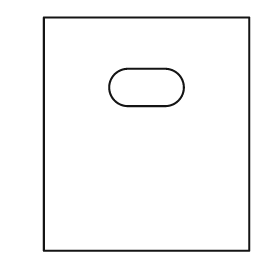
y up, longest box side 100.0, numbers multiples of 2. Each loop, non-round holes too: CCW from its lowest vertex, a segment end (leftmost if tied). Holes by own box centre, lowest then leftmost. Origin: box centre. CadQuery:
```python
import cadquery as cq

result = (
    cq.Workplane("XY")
    .moveTo(-44.0, -50.0)
    .lineTo(44.0, -50.0)
    .lineTo(44.0, 50.0)
    .lineTo(-44.0, 50.0)
    .close()
    .moveTo(-8.0, 12.0)
    .lineTo(8.0, 12.0)
    .threePointArc((16.0, 20.0), (8.0, 28.0))
    .lineTo(-8.0, 28.0)
    .threePointArc((-16.0, 20.0), (-8.0, 12.0))
    .close()
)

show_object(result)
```